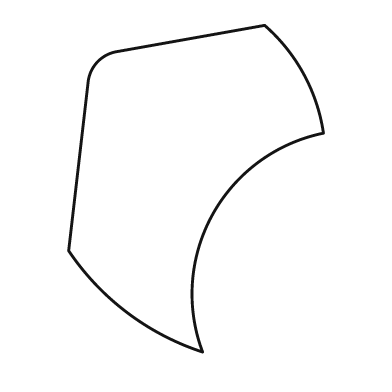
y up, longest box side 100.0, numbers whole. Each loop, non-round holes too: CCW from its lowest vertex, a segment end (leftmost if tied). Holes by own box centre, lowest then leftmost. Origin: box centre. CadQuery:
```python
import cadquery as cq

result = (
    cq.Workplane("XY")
    .moveTo(2.0, -50.0)
    .threePointArc((5.0, -8.0), (39.0, 17.0))
    .threePointArc((33.0, 35.0), (21.0, 50.0))
    .lineTo(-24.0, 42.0)
    .threePointArc((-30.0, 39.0), (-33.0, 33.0))
    .lineTo(-39.0, -19.0)
    .threePointArc((-21.0, -38.0), (2.0, -50.0))
    .close()
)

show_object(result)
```